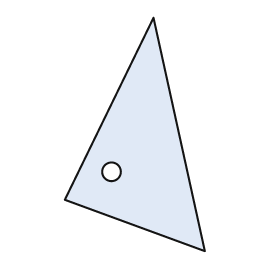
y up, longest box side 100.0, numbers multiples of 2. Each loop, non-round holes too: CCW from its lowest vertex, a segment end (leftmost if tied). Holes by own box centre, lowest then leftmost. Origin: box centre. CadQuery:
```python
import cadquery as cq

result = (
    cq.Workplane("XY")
    .moveTo(30.0, -50.0)
    .lineTo(8.0, 50.0)
    .lineTo(-30.0, -28.0)
    .close()
    .moveTo(-10.0, -16.0)
    .circle(4.0)
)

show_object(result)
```